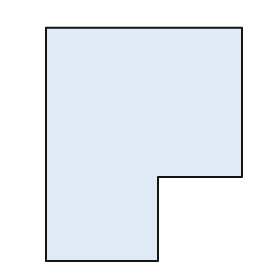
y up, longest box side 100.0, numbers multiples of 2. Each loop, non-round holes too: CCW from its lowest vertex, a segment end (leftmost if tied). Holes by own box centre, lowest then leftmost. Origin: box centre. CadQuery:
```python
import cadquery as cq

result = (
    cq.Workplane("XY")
    .moveTo(-42.0, -50.0)
    .lineTo(6.0, -50.0)
    .lineTo(6.0, -14.0)
    .lineTo(42.0, -14.0)
    .lineTo(42.0, 50.0)
    .lineTo(-42.0, 50.0)
    .close()
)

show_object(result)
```